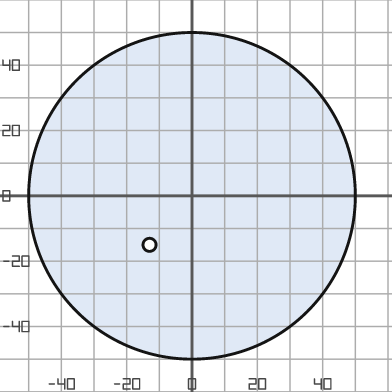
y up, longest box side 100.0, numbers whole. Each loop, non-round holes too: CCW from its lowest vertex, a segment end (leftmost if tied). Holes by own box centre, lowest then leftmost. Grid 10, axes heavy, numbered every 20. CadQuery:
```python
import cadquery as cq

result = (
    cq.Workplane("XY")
    .moveTo(0.0, 0.0)
    .circle(50.0)
    .moveTo(-13.0, -15.0)
    .circle(2.0)
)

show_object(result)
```